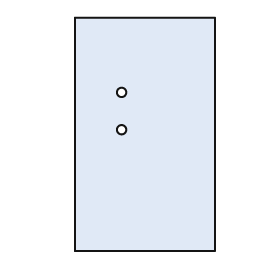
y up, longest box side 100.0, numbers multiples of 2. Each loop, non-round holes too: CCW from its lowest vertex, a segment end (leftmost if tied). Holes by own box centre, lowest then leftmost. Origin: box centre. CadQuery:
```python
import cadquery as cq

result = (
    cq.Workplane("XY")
    .moveTo(-30.0, -50.0)
    .lineTo(30.0, -50.0)
    .lineTo(30.0, 50.0)
    .lineTo(-30.0, 50.0)
    .close()
    .moveTo(-10.0, 2.0)
    .circle(2.0)
    .moveTo(-10.0, 18.0)
    .circle(2.0)
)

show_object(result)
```